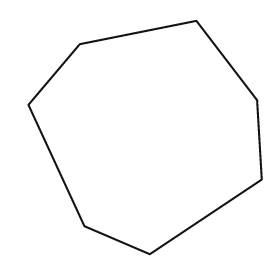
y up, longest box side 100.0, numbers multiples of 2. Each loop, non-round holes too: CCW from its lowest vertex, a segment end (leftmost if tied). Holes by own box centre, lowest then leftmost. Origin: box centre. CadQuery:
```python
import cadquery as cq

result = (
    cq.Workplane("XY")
    .moveTo(2.0, -50.0)
    .lineTo(50.0, -18.0)
    .lineTo(48.0, 16.0)
    .lineTo(22.0, 50.0)
    .lineTo(-28.0, 40.0)
    .lineTo(-50.0, 14.0)
    .lineTo(-26.0, -38.0)
    .close()
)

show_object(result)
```